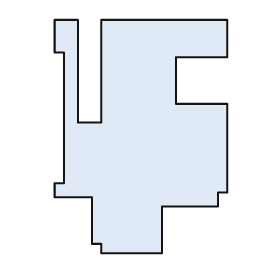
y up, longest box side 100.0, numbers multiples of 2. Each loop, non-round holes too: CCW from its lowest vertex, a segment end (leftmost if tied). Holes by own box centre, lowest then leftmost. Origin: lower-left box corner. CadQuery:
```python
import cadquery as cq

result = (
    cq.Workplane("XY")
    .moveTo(20.0, 0.0)
    .lineTo(46.0, 0.0)
    .lineTo(46.0, 20.0)
    .lineTo(70.0, 20.0)
    .lineTo(70.0, 26.0)
    .lineTo(74.0, 26.0)
    .lineTo(74.0, 64.0)
    .lineTo(52.0, 64.0)
    .lineTo(52.0, 84.0)
    .lineTo(74.0, 84.0)
    .lineTo(74.0, 100.0)
    .lineTo(20.0, 100.0)
    .lineTo(20.0, 56.0)
    .lineTo(10.0, 56.0)
    .lineTo(10.0, 100.0)
    .lineTo(0.0, 100.0)
    .lineTo(0.0, 86.0)
    .lineTo(4.0, 86.0)
    .lineTo(4.0, 30.0)
    .lineTo(0.0, 30.0)
    .lineTo(0.0, 24.0)
    .lineTo(16.0, 24.0)
    .lineTo(16.0, 4.0)
    .lineTo(20.0, 4.0)
    .close()
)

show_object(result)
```